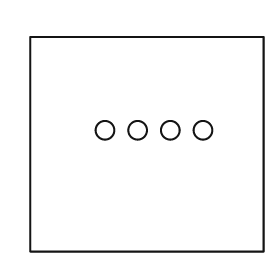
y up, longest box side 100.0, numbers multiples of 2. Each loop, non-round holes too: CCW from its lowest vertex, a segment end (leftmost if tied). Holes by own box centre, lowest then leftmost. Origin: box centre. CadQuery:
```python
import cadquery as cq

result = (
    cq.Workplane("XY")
    .moveTo(-50.0, -46.0)
    .lineTo(50.0, -46.0)
    .lineTo(50.0, 46.0)
    .lineTo(-50.0, 46.0)
    .close()
    .moveTo(-18.0, 6.0)
    .circle(4.0)
    .moveTo(-4.0, 6.0)
    .circle(4.0)
    .moveTo(10.0, 6.0)
    .circle(4.0)
    .moveTo(24.0, 6.0)
    .circle(4.0)
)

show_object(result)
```